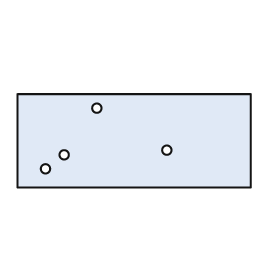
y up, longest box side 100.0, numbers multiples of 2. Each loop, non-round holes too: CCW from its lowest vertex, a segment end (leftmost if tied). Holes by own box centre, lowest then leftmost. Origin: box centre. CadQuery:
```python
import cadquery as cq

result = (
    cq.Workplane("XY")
    .moveTo(-50.0, -20.0)
    .lineTo(50.0, -20.0)
    .lineTo(50.0, 20.0)
    .lineTo(-50.0, 20.0)
    .close()
    .moveTo(-38.0, -12.0)
    .circle(2.0)
    .moveTo(-30.0, -6.0)
    .circle(2.0)
    .moveTo(14.0, -4.0)
    .circle(2.0)
    .moveTo(-16.0, 14.0)
    .circle(2.0)
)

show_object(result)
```